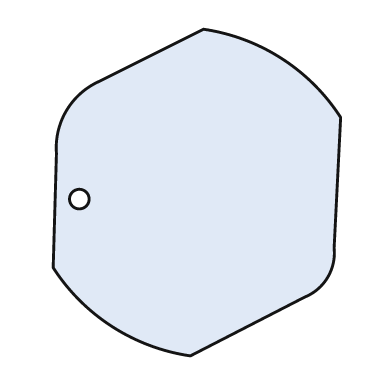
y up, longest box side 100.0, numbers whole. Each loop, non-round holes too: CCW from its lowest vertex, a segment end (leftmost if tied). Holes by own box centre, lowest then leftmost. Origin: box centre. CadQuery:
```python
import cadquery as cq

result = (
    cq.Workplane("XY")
    .moveTo(-2.0, -50.0)
    .lineTo(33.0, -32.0)
    .threePointArc((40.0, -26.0), (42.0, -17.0))
    .lineTo(44.0, 23.0)
    .threePointArc((26.0, 41.0), (2.0, 50.0))
    .lineTo(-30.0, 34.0)
    .threePointArc((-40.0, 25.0), (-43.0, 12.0))
    .lineTo(-44.0, -23.0)
    .threePointArc((-26.0, -41.0), (-2.0, -50.0))
    .close()
    .moveTo(-36.0, -2.0)
    .circle(3.0)
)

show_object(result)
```